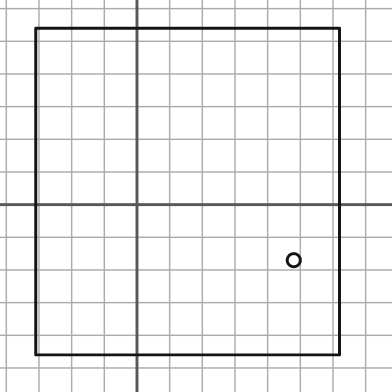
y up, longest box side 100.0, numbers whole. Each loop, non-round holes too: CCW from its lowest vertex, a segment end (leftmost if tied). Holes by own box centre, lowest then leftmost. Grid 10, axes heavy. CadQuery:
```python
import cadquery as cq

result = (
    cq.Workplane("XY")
    .moveTo(-31.0, -46.0)
    .lineTo(62.0, -46.0)
    .lineTo(62.0, 54.0)
    .lineTo(-31.0, 54.0)
    .close()
    .moveTo(48.0, -17.0)
    .circle(2.0)
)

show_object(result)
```